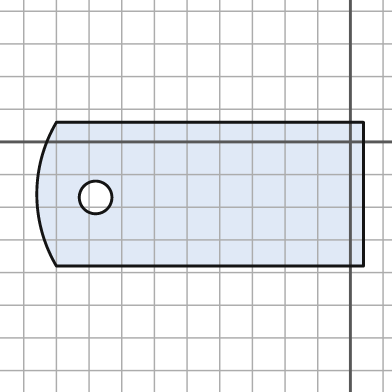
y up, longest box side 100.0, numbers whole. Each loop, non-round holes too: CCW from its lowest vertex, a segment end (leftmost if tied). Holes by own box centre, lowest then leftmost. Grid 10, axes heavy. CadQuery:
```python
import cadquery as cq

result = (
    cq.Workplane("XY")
    .moveTo(-90.0, -38.0)
    .lineTo(4.0, -38.0)
    .lineTo(4.0, 6.0)
    .lineTo(-90.0, 6.0)
    .threePointArc((-96.0, -16.0), (-90.0, -38.0))
    .close()
    .moveTo(-78.0, -17.0)
    .circle(5.0)
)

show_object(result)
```